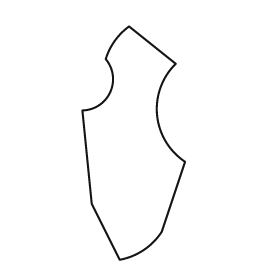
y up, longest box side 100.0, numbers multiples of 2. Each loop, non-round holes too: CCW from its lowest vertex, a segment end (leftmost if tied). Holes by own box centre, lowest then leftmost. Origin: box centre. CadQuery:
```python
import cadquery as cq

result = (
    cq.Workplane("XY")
    .moveTo(-6.0, -50.0)
    .threePointArc((4.0, -46.0), (12.0, -38.0))
    .lineTo(22.0, -8.0)
    .threePointArc((10.0, 12.0), (18.0, 34.0))
    .lineTo(-2.0, 50.0)
    .threePointArc((-8.0, 44.0), (-12.0, 36.0))
    .threePointArc((-10.0, 22.0), (-22.0, 14.0))
    .lineTo(-18.0, -26.0)
    .close()
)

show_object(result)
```